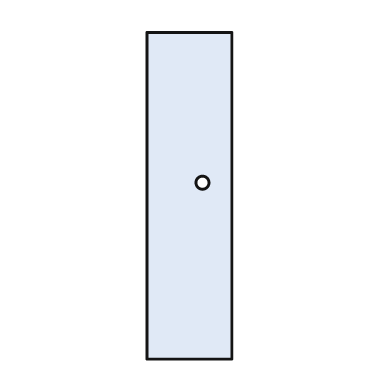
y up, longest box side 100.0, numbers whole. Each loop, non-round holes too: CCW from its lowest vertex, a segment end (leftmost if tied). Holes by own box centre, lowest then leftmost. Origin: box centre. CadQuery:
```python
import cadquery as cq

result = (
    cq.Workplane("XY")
    .moveTo(-13.0, -50.0)
    .lineTo(13.0, -50.0)
    .lineTo(13.0, 50.0)
    .lineTo(-13.0, 50.0)
    .close()
    .moveTo(4.0, 4.0)
    .circle(2.0)
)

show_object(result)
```